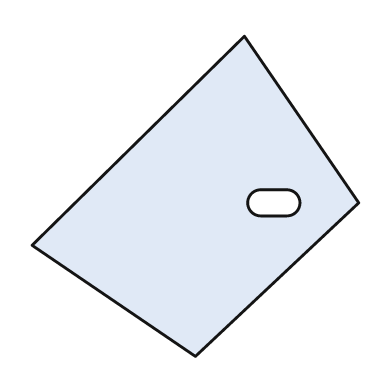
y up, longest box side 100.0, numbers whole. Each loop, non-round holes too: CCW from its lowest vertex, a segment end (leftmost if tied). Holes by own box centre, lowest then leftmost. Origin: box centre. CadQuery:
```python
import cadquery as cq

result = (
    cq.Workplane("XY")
    .moveTo(0.0, -49.0)
    .lineTo(50.0, -2.0)
    .lineTo(15.0, 49.0)
    .lineTo(-50.0, -15.0)
    .close()
    .moveTo(20.0, -6.0)
    .lineTo(28.0, -6.0)
    .threePointArc((32.0, -2.0), (28.0, 2.0))
    .lineTo(20.0, 2.0)
    .threePointArc((16.0, -2.0), (20.0, -6.0))
    .close()
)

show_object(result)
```